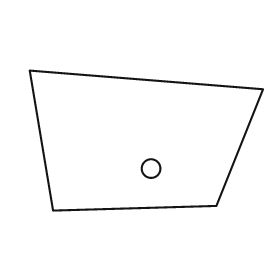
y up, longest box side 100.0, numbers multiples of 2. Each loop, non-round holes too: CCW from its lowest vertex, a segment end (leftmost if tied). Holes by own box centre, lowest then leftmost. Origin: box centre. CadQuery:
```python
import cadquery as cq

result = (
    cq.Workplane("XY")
    .moveTo(-40.0, -30.0)
    .lineTo(30.0, -28.0)
    .lineTo(50.0, 22.0)
    .lineTo(-50.0, 30.0)
    .close()
    .moveTo(2.0, -12.0)
    .circle(4.0)
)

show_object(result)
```